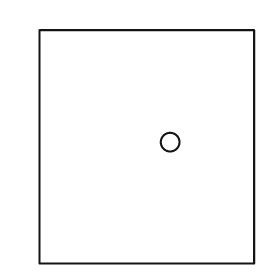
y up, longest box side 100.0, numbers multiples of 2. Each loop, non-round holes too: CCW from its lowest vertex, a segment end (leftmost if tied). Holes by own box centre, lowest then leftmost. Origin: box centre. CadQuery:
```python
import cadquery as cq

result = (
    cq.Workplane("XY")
    .moveTo(-46.0, -50.0)
    .lineTo(46.0, -50.0)
    .lineTo(46.0, 50.0)
    .lineTo(-46.0, 50.0)
    .close()
    .moveTo(10.0, 2.0)
    .circle(4.0)
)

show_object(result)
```